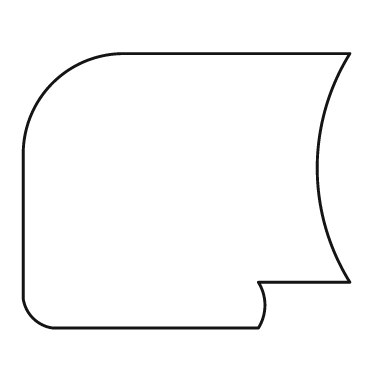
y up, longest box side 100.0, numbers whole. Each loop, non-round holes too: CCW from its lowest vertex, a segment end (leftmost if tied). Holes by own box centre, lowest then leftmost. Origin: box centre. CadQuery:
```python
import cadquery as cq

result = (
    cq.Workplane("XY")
    .moveTo(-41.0, -42.0)
    .lineTo(22.0, -42.0)
    .threePointArc((24.0, -35.0), (22.0, -28.0))
    .lineTo(50.0, -28.0)
    .threePointArc((40.0, 7.0), (50.0, 42.0))
    .lineTo(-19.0, 42.0)
    .threePointArc((-41.0, 33.0), (-50.0, 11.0))
    .lineTo(-50.0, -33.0)
    .threePointArc((-47.0, -39.0), (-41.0, -42.0))
    .close()
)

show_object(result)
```